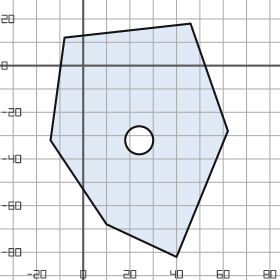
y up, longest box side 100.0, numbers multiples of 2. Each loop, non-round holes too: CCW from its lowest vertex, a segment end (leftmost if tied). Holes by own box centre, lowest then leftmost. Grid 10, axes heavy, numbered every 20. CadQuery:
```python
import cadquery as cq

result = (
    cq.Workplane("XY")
    .moveTo(40.0, -82.0)
    .lineTo(62.0, -28.0)
    .lineTo(46.0, 18.0)
    .lineTo(-8.0, 12.0)
    .lineTo(-14.0, -32.0)
    .lineTo(10.0, -68.0)
    .close()
    .moveTo(24.0, -32.0)
    .circle(6.0)
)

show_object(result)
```